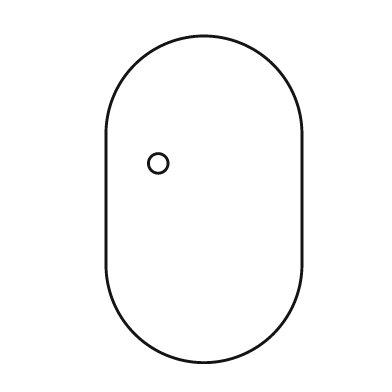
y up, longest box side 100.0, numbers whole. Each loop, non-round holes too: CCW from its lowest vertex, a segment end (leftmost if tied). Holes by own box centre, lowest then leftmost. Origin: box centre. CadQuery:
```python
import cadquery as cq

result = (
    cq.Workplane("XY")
    .moveTo(-30.0, -20.0)
    .threePointArc((0.0, -50.0), (30.0, -20.0))
    .lineTo(30.0, 20.0)
    .threePointArc((0.0, 50.0), (-30.0, 20.0))
    .close()
    .moveTo(-14.0, 11.0)
    .circle(3.0)
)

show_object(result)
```